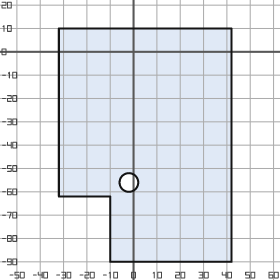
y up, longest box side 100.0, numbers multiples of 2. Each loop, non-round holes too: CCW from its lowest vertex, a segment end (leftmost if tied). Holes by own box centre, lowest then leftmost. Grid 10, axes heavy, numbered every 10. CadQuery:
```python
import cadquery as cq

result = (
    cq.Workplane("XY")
    .moveTo(-10.0, -90.0)
    .lineTo(42.0, -90.0)
    .lineTo(42.0, 10.0)
    .lineTo(-32.0, 10.0)
    .lineTo(-32.0, -62.0)
    .lineTo(-10.0, -62.0)
    .close()
    .moveTo(-2.0, -56.0)
    .circle(4.0)
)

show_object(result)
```